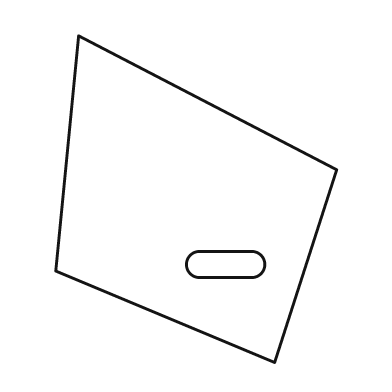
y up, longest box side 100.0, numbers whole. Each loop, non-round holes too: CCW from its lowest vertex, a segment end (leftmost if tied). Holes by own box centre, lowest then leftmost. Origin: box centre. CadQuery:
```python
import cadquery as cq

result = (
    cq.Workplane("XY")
    .moveTo(24.0, -50.0)
    .lineTo(43.0, 9.0)
    .lineTo(-36.0, 50.0)
    .lineTo(-43.0, -22.0)
    .close()
    .moveTo(1.0, -24.0)
    .lineTo(17.0, -24.0)
    .threePointArc((21.0, -20.0), (17.0, -16.0))
    .lineTo(1.0, -16.0)
    .threePointArc((-3.0, -20.0), (1.0, -24.0))
    .close()
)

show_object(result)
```